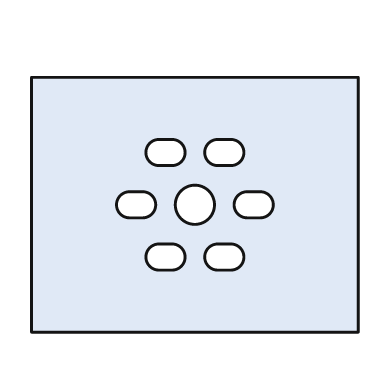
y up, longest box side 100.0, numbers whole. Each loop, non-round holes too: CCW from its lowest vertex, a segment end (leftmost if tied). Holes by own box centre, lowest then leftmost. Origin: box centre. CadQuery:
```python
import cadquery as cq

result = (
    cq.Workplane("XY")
    .moveTo(-50.0, -39.0)
    .lineTo(50.0, -39.0)
    .lineTo(50.0, 39.0)
    .lineTo(-50.0, 39.0)
    .close()
    .moveTo(-11.0, -20.0)
    .lineTo(-7.0, -20.0)
    .threePointArc((-3.0, -16.0), (-7.0, -12.0))
    .lineTo(-11.0, -12.0)
    .threePointArc((-15.0, -16.0), (-11.0, -20.0))
    .close()
    .moveTo(7.0, -20.0)
    .lineTo(11.0, -20.0)
    .threePointArc((15.0, -16.0), (11.0, -12.0))
    .lineTo(7.0, -12.0)
    .threePointArc((3.0, -16.0), (7.0, -20.0))
    .close()
    .moveTo(-20.0, -4.0)
    .lineTo(-16.0, -4.0)
    .threePointArc((-12.0, 0.0), (-16.0, 4.0))
    .lineTo(-20.0, 4.0)
    .threePointArc((-24.0, 0.0), (-20.0, -4.0))
    .close()
    .moveTo(0.0, 0.0)
    .circle(6.0)
    .moveTo(16.0, -4.0)
    .lineTo(20.0, -4.0)
    .threePointArc((24.0, 0.0), (20.0, 4.0))
    .lineTo(16.0, 4.0)
    .threePointArc((12.0, 0.0), (16.0, -4.0))
    .close()
    .moveTo(-11.0, 12.0)
    .lineTo(-7.0, 12.0)
    .threePointArc((-3.0, 16.0), (-7.0, 20.0))
    .lineTo(-11.0, 20.0)
    .threePointArc((-15.0, 16.0), (-11.0, 12.0))
    .close()
    .moveTo(7.0, 12.0)
    .lineTo(11.0, 12.0)
    .threePointArc((15.0, 16.0), (11.0, 20.0))
    .lineTo(7.0, 20.0)
    .threePointArc((3.0, 16.0), (7.0, 12.0))
    .close()
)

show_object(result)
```